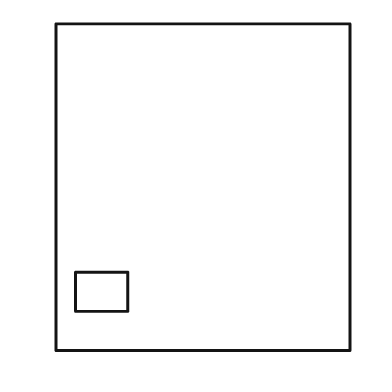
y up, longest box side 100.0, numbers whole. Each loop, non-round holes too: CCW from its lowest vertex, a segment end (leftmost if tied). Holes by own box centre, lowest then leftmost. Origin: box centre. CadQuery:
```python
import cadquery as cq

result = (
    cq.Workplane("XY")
    .moveTo(-45.0, -50.0)
    .lineTo(45.0, -50.0)
    .lineTo(45.0, 50.0)
    .lineTo(-45.0, 50.0)
    .close()
    .moveTo(-39.0, -38.0)
    .lineTo(-23.0, -38.0)
    .lineTo(-23.0, -26.0)
    .lineTo(-39.0, -26.0)
    .close()
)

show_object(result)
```